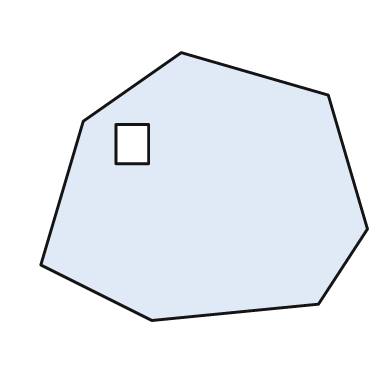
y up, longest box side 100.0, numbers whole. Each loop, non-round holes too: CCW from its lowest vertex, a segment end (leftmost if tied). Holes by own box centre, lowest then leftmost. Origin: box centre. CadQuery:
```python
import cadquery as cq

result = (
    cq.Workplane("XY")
    .moveTo(-16.0, -41.0)
    .lineTo(35.0, -36.0)
    .lineTo(50.0, -13.0)
    .lineTo(38.0, 28.0)
    .lineTo(-7.0, 41.0)
    .lineTo(-37.0, 20.0)
    .lineTo(-50.0, -24.0)
    .close()
    .moveTo(-27.0, 7.0)
    .lineTo(-17.0, 7.0)
    .lineTo(-17.0, 19.0)
    .lineTo(-27.0, 19.0)
    .close()
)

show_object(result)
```